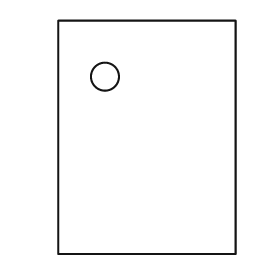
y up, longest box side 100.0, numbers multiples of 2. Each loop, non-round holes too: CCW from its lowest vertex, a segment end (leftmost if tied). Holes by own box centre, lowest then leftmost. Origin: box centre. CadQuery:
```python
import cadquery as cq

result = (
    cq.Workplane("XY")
    .moveTo(-38.0, -50.0)
    .lineTo(38.0, -50.0)
    .lineTo(38.0, 50.0)
    .lineTo(-38.0, 50.0)
    .close()
    .moveTo(-18.0, 26.0)
    .circle(6.0)
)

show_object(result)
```